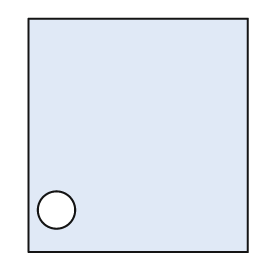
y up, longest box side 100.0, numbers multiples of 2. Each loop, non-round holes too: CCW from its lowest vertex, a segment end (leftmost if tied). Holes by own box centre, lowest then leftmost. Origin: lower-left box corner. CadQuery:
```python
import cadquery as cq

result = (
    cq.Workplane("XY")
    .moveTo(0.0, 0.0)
    .lineTo(94.0, 0.0)
    .lineTo(94.0, 100.0)
    .lineTo(0.0, 100.0)
    .close()
    .moveTo(12.0, 18.0)
    .circle(8.0)
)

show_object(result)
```